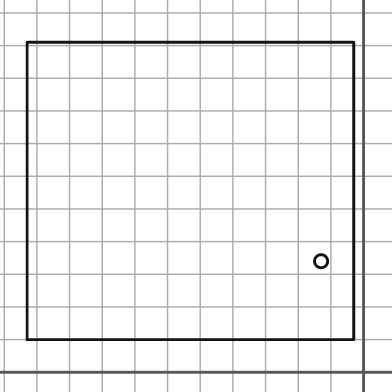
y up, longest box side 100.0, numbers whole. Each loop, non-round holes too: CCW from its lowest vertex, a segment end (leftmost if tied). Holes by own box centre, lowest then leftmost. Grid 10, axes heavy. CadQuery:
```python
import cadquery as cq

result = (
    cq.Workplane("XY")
    .moveTo(-103.0, 10.0)
    .lineTo(-3.0, 10.0)
    .lineTo(-3.0, 101.0)
    .lineTo(-103.0, 101.0)
    .close()
    .moveTo(-13.0, 34.0)
    .circle(2.0)
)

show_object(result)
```